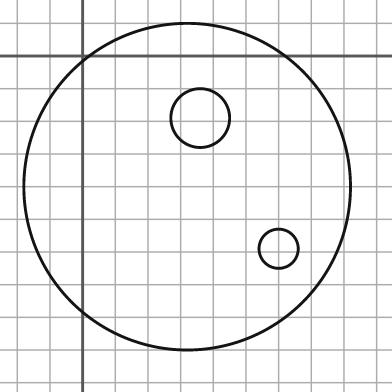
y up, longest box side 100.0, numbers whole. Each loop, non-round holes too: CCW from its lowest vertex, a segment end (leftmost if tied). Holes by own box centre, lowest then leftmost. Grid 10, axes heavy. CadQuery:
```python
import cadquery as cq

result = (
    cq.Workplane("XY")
    .moveTo(32.0, -40.0)
    .circle(50.0)
    .moveTo(60.0, -59.0)
    .circle(6.0)
    .moveTo(36.0, -19.0)
    .circle(9.0)
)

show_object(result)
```